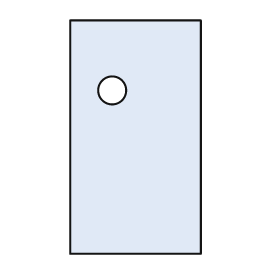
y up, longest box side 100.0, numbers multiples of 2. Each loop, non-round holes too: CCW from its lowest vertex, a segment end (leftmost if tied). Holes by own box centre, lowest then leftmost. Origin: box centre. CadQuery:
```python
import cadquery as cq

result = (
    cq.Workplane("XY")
    .moveTo(-28.0, -50.0)
    .lineTo(28.0, -50.0)
    .lineTo(28.0, 50.0)
    .lineTo(-28.0, 50.0)
    .close()
    .moveTo(-10.0, 20.0)
    .circle(6.0)
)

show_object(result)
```